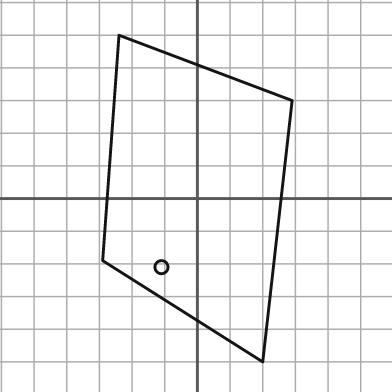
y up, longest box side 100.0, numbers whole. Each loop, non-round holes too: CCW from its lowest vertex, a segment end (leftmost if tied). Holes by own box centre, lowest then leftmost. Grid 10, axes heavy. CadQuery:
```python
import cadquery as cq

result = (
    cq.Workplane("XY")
    .moveTo(20.0, -50.0)
    .lineTo(29.0, 30.0)
    .lineTo(-24.0, 50.0)
    .lineTo(-29.0, -19.0)
    .close()
    .moveTo(-11.0, -21.0)
    .circle(2.0)
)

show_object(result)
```